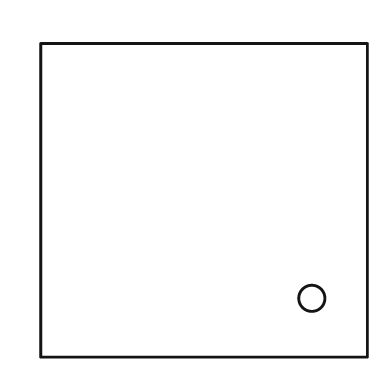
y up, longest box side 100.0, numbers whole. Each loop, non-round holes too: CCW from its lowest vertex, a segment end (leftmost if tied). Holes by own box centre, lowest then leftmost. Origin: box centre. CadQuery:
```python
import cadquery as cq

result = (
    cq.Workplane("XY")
    .moveTo(-50.0, -48.0)
    .lineTo(50.0, -48.0)
    .lineTo(50.0, 48.0)
    .lineTo(-50.0, 48.0)
    .close()
    .moveTo(33.0, -30.0)
    .circle(4.0)
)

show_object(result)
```